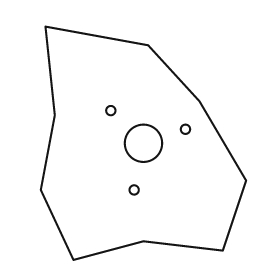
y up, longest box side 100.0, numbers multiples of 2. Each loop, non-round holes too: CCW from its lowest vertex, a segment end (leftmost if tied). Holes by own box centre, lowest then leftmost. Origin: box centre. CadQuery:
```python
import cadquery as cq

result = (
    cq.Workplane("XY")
    .moveTo(-30.0, -50.0)
    .lineTo(0.0, -42.0)
    .lineTo(34.0, -46.0)
    .lineTo(44.0, -16.0)
    .lineTo(24.0, 18.0)
    .lineTo(2.0, 42.0)
    .lineTo(-42.0, 50.0)
    .lineTo(-38.0, 12.0)
    .lineTo(-44.0, -20.0)
    .close()
    .moveTo(-4.0, -20.0)
    .circle(2.0)
    .moveTo(0.0, 0.0)
    .circle(8.0)
    .moveTo(18.0, 6.0)
    .circle(2.0)
    .moveTo(-14.0, 14.0)
    .circle(2.0)
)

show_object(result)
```